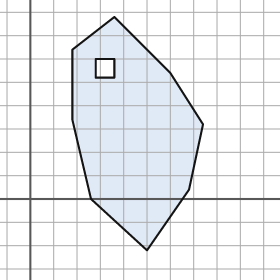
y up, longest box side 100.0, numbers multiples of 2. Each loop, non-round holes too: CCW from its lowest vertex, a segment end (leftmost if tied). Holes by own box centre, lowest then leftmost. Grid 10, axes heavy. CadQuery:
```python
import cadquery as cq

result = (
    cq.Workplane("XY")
    .moveTo(50.0, -22.0)
    .lineTo(68.0, 4.0)
    .lineTo(74.0, 32.0)
    .lineTo(60.0, 54.0)
    .lineTo(36.0, 78.0)
    .lineTo(18.0, 64.0)
    .lineTo(18.0, 34.0)
    .lineTo(26.0, 0.0)
    .close()
    .moveTo(28.0, 52.0)
    .lineTo(36.0, 52.0)
    .lineTo(36.0, 60.0)
    .lineTo(28.0, 60.0)
    .close()
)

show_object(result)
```